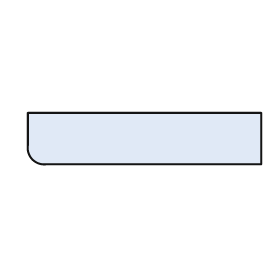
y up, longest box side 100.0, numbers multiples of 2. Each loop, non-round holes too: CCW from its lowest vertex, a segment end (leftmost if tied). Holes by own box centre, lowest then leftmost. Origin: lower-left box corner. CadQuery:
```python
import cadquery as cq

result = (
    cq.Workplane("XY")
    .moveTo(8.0, 0.0)
    .lineTo(100.0, 0.0)
    .lineTo(100.0, 22.0)
    .lineTo(0.0, 22.0)
    .lineTo(0.0, 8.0)
    .threePointArc((2.0, 2.0), (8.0, 0.0))
    .close()
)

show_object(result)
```